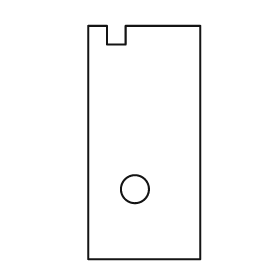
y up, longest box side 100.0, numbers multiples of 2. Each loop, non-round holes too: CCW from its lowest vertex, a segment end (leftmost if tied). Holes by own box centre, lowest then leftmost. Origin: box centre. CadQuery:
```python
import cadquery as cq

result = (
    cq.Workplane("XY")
    .moveTo(-24.0, -50.0)
    .lineTo(24.0, -50.0)
    .lineTo(24.0, 50.0)
    .lineTo(-8.0, 50.0)
    .lineTo(-8.0, 42.0)
    .lineTo(-16.0, 42.0)
    .lineTo(-16.0, 50.0)
    .lineTo(-24.0, 50.0)
    .close()
    .moveTo(-4.0, -20.0)
    .circle(6.0)
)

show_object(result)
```